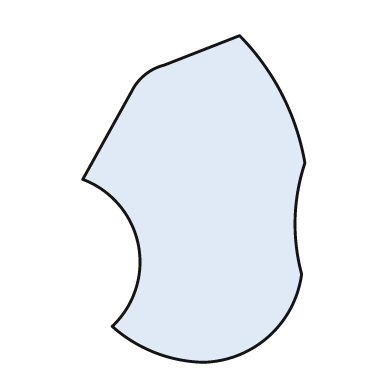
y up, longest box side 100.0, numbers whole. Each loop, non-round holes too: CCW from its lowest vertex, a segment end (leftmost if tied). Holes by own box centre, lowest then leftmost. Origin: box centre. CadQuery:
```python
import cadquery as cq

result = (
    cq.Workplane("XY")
    .moveTo(3.0, -50.0)
    .threePointArc((23.0, -42.0), (33.0, -23.0))
    .threePointArc((31.0, -6.0), (34.0, 11.0))
    .threePointArc((27.0, 32.0), (14.0, 50.0))
    .lineTo(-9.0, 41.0)
    .threePointArc((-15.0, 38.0), (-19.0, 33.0))
    .lineTo(-34.0, 6.0)
    .threePointArc((-17.0, -14.0), (-25.0, -39.0))
    .threePointArc((-12.0, -47.0), (3.0, -50.0))
    .close()
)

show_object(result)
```